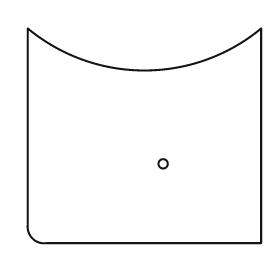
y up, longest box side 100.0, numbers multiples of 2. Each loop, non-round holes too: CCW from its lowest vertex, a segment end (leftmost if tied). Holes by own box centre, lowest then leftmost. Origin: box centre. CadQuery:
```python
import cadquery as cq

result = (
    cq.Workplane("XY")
    .moveTo(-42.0, -46.0)
    .lineTo(50.0, -46.0)
    .lineTo(50.0, 46.0)
    .threePointArc((0.0, 28.0), (-50.0, 46.0))
    .lineTo(-50.0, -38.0)
    .threePointArc((-48.0, -44.0), (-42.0, -46.0))
    .close()
    .moveTo(8.0, -12.0)
    .circle(2.0)
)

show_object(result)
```